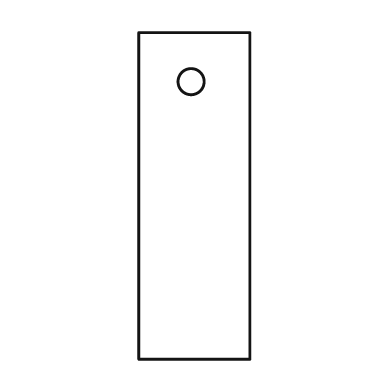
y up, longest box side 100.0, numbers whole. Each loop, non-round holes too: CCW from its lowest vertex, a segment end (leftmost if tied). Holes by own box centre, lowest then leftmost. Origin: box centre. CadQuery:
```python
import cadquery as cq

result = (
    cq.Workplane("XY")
    .moveTo(-17.0, -50.0)
    .lineTo(17.0, -50.0)
    .lineTo(17.0, 50.0)
    .lineTo(-17.0, 50.0)
    .close()
    .moveTo(-1.0, 35.0)
    .circle(4.0)
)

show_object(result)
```